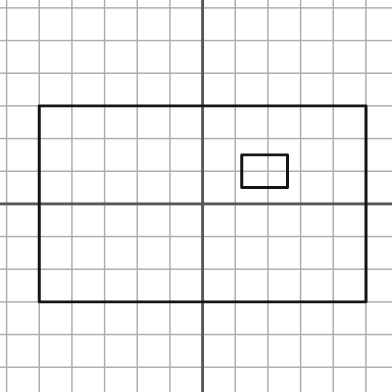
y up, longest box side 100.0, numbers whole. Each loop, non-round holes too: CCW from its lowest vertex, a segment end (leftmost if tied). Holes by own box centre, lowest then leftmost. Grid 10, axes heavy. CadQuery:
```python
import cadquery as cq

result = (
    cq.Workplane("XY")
    .moveTo(-50.0, -30.0)
    .lineTo(50.0, -30.0)
    .lineTo(50.0, 30.0)
    .lineTo(-50.0, 30.0)
    .close()
    .moveTo(12.0, 5.0)
    .lineTo(26.0, 5.0)
    .lineTo(26.0, 15.0)
    .lineTo(12.0, 15.0)
    .close()
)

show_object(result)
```